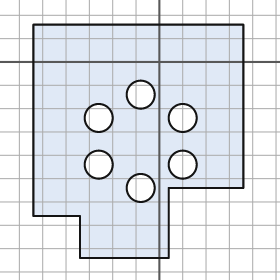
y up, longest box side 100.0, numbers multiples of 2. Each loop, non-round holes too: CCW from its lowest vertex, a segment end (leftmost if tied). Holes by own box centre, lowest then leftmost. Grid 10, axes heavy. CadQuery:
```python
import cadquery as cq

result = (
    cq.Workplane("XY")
    .moveTo(-34.0, -84.0)
    .lineTo(4.0, -84.0)
    .lineTo(4.0, -54.0)
    .lineTo(36.0, -54.0)
    .lineTo(36.0, 16.0)
    .lineTo(-54.0, 16.0)
    .lineTo(-54.0, -66.0)
    .lineTo(-34.0, -66.0)
    .close()
    .moveTo(-8.0, -54.0)
    .circle(6.0)
    .moveTo(-26.0, -44.0)
    .circle(6.0)
    .moveTo(10.0, -44.0)
    .circle(6.0)
    .moveTo(-26.0, -24.0)
    .circle(6.0)
    .moveTo(10.0, -24.0)
    .circle(6.0)
    .moveTo(-8.0, -14.0)
    .circle(6.0)
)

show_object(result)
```